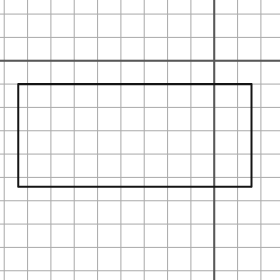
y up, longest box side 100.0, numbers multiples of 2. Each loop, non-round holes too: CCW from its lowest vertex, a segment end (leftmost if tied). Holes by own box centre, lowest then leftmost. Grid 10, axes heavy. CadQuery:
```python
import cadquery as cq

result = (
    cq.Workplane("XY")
    .moveTo(-84.0, -54.0)
    .lineTo(16.0, -54.0)
    .lineTo(16.0, -10.0)
    .lineTo(-84.0, -10.0)
    .close()
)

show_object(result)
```